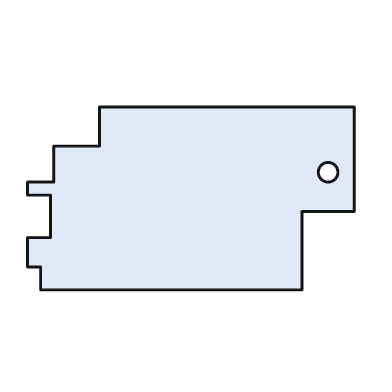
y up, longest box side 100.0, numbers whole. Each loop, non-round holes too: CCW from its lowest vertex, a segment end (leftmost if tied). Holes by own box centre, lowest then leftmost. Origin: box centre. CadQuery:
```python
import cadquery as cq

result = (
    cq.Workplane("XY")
    .moveTo(-46.0, -28.0)
    .lineTo(34.0, -28.0)
    .lineTo(34.0, -4.0)
    .lineTo(50.0, -4.0)
    .lineTo(50.0, 28.0)
    .lineTo(-28.0, 28.0)
    .lineTo(-28.0, 16.0)
    .lineTo(-42.0, 16.0)
    .lineTo(-42.0, 5.0)
    .lineTo(-50.0, 5.0)
    .lineTo(-50.0, 1.0)
    .lineTo(-43.0, 1.0)
    .lineTo(-43.0, -12.0)
    .lineTo(-50.0, -12.0)
    .lineTo(-50.0, -21.0)
    .lineTo(-46.0, -21.0)
    .close()
    .moveTo(42.0, 8.0)
    .circle(3.0)
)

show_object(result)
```